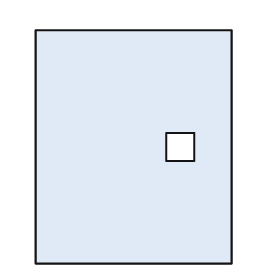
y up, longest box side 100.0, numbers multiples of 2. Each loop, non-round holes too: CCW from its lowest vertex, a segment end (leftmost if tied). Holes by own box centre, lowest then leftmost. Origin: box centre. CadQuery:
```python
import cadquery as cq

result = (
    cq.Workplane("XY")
    .moveTo(-42.0, -50.0)
    .lineTo(42.0, -50.0)
    .lineTo(42.0, 50.0)
    .lineTo(-42.0, 50.0)
    .close()
    .moveTo(14.0, -6.0)
    .lineTo(26.0, -6.0)
    .lineTo(26.0, 6.0)
    .lineTo(14.0, 6.0)
    .close()
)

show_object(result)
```